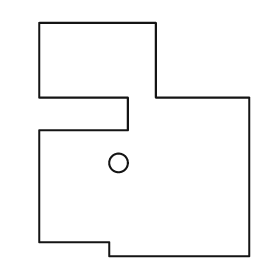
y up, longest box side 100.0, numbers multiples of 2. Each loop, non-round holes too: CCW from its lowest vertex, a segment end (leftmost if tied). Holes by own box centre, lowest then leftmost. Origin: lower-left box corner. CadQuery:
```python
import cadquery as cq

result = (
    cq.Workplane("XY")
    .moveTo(30.0, 0.0)
    .lineTo(90.0, 0.0)
    .lineTo(90.0, 68.0)
    .lineTo(50.0, 68.0)
    .lineTo(50.0, 100.0)
    .lineTo(0.0, 100.0)
    .lineTo(0.0, 68.0)
    .lineTo(38.0, 68.0)
    .lineTo(38.0, 54.0)
    .lineTo(0.0, 54.0)
    .lineTo(0.0, 6.0)
    .lineTo(30.0, 6.0)
    .close()
    .moveTo(34.0, 40.0)
    .circle(4.0)
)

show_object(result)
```